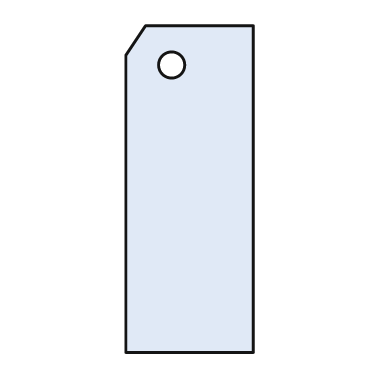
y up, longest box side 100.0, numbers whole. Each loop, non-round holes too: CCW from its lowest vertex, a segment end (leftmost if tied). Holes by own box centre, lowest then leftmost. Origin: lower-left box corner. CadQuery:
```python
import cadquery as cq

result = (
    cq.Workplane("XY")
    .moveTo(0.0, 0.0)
    .lineTo(39.0, 0.0)
    .lineTo(39.0, 100.0)
    .lineTo(6.0, 100.0)
    .lineTo(0.0, 91.0)
    .close()
    .moveTo(14.0, 88.0)
    .circle(4.0)
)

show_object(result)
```